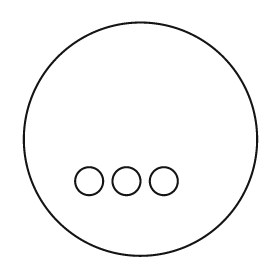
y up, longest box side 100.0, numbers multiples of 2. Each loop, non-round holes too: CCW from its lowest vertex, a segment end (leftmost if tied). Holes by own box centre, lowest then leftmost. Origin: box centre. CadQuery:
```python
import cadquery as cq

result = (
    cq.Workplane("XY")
    .moveTo(0.0, 0.0)
    .circle(50.0)
    .moveTo(-22.0, -18.0)
    .circle(6.0)
    .moveTo(-6.0, -18.0)
    .circle(6.0)
    .moveTo(10.0, -18.0)
    .circle(6.0)
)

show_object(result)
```